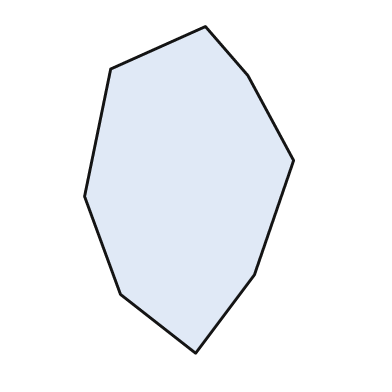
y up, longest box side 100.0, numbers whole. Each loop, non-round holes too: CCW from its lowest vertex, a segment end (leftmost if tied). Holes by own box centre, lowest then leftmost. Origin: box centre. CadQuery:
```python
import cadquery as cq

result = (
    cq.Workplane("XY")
    .moveTo(2.0, -50.0)
    .lineTo(20.0, -26.0)
    .lineTo(32.0, 9.0)
    .lineTo(18.0, 35.0)
    .lineTo(5.0, 50.0)
    .lineTo(-24.0, 37.0)
    .lineTo(-32.0, -2.0)
    .lineTo(-21.0, -32.0)
    .close()
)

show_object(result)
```